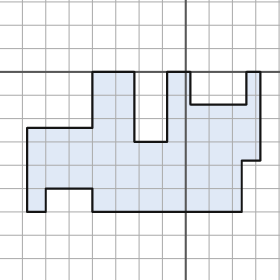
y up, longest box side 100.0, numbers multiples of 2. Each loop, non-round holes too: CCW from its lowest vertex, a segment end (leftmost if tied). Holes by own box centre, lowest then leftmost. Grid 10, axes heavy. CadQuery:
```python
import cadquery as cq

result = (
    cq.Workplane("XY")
    .moveTo(-68.0, -60.0)
    .lineTo(-60.0, -60.0)
    .lineTo(-60.0, -50.0)
    .lineTo(-40.0, -50.0)
    .lineTo(-40.0, -60.0)
    .lineTo(24.0, -60.0)
    .lineTo(24.0, -38.0)
    .lineTo(32.0, -38.0)
    .lineTo(32.0, 0.0)
    .lineTo(26.0, 0.0)
    .lineTo(26.0, -14.0)
    .lineTo(2.0, -14.0)
    .lineTo(2.0, 0.0)
    .lineTo(-8.0, 0.0)
    .lineTo(-8.0, -30.0)
    .lineTo(-22.0, -30.0)
    .lineTo(-22.0, 0.0)
    .lineTo(-40.0, 0.0)
    .lineTo(-40.0, -24.0)
    .lineTo(-68.0, -24.0)
    .close()
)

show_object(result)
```